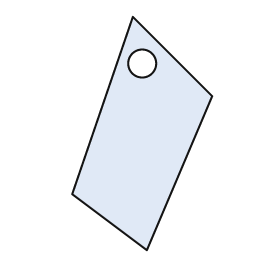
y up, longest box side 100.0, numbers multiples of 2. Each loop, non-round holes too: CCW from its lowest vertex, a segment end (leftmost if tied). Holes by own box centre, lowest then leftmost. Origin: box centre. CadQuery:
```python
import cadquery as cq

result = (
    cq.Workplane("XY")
    .moveTo(2.0, -50.0)
    .lineTo(30.0, 16.0)
    .lineTo(-4.0, 50.0)
    .lineTo(-30.0, -26.0)
    .close()
    .moveTo(0.0, 30.0)
    .circle(6.0)
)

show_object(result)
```